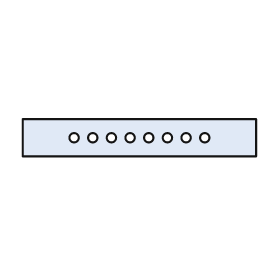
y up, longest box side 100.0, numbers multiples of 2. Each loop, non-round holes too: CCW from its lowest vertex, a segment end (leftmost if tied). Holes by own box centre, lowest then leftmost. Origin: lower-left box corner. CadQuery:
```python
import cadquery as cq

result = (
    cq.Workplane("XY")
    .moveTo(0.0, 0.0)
    .lineTo(100.0, 0.0)
    .lineTo(100.0, 16.0)
    .lineTo(0.0, 16.0)
    .close()
    .moveTo(22.0, 8.0)
    .circle(2.0)
    .moveTo(30.0, 8.0)
    .circle(2.0)
    .moveTo(38.0, 8.0)
    .circle(2.0)
    .moveTo(46.0, 8.0)
    .circle(2.0)
    .moveTo(54.0, 8.0)
    .circle(2.0)
    .moveTo(62.0, 8.0)
    .circle(2.0)
    .moveTo(70.0, 8.0)
    .circle(2.0)
    .moveTo(78.0, 8.0)
    .circle(2.0)
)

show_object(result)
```